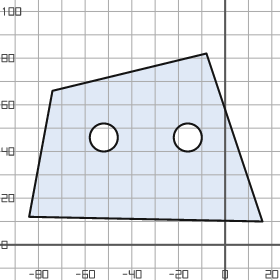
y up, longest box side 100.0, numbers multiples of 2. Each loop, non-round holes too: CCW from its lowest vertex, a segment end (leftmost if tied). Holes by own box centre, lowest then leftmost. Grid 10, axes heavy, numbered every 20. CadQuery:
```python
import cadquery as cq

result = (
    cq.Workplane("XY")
    .moveTo(16.0, 10.0)
    .lineTo(-8.0, 82.0)
    .lineTo(-74.0, 66.0)
    .lineTo(-84.0, 12.0)
    .close()
    .moveTo(-52.0, 46.0)
    .circle(6.0)
    .moveTo(-16.0, 46.0)
    .circle(6.0)
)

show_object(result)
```